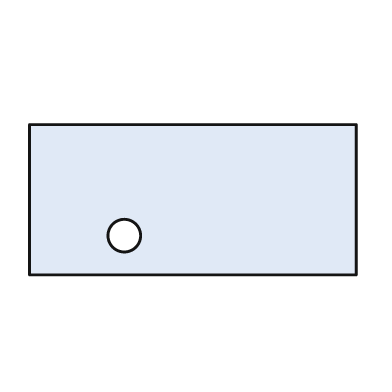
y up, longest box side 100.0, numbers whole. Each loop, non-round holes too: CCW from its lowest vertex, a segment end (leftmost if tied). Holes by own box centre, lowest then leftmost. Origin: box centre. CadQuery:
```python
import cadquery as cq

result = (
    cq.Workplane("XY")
    .moveTo(-50.0, -23.0)
    .lineTo(50.0, -23.0)
    .lineTo(50.0, 23.0)
    .lineTo(-50.0, 23.0)
    .close()
    .moveTo(-21.0, -11.0)
    .circle(5.0)
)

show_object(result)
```